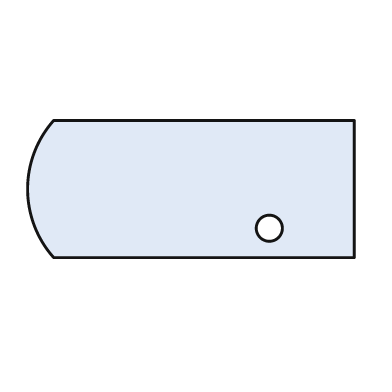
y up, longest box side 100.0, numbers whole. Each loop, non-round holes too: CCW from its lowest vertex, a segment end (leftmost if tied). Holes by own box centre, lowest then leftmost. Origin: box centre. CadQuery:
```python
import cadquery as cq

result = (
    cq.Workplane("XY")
    .moveTo(-42.0, -21.0)
    .lineTo(50.0, -21.0)
    .lineTo(50.0, 21.0)
    .lineTo(-42.0, 21.0)
    .threePointArc((-50.0, 0.0), (-42.0, -21.0))
    .close()
    .moveTo(24.0, -12.0)
    .circle(4.0)
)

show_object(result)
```